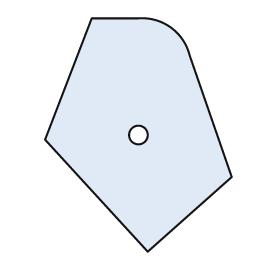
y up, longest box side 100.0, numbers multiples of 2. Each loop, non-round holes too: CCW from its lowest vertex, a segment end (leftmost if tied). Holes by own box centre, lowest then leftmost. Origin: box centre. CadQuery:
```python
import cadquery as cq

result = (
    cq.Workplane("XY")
    .moveTo(4.0, -50.0)
    .lineTo(40.0, -18.0)
    .lineTo(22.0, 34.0)
    .threePointArc((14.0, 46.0), (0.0, 50.0))
    .lineTo(-20.0, 50.0)
    .lineTo(-40.0, -2.0)
    .close()
    .moveTo(0.0, 0.0)
    .circle(4.0)
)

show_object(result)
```